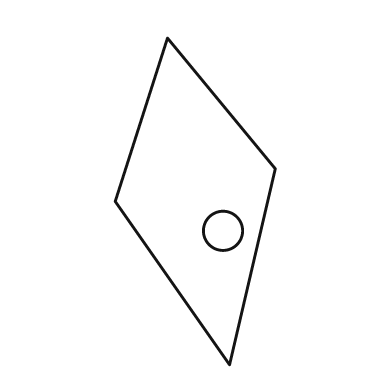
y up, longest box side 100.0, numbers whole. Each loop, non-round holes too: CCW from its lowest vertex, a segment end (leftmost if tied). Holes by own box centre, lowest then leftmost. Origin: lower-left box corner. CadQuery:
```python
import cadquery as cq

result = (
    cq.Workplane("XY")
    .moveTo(35.0, 0.0)
    .lineTo(49.0, 60.0)
    .lineTo(16.0, 100.0)
    .lineTo(0.0, 50.0)
    .close()
    .moveTo(33.0, 41.0)
    .circle(6.0)
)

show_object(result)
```